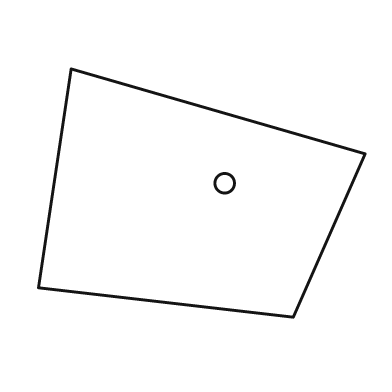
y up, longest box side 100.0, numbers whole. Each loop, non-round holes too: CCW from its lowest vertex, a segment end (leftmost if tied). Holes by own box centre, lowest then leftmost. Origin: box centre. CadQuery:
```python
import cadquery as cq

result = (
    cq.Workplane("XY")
    .moveTo(28.0, -38.0)
    .lineTo(50.0, 12.0)
    .lineTo(-40.0, 38.0)
    .lineTo(-50.0, -29.0)
    .close()
    .moveTo(7.0, 3.0)
    .circle(3.0)
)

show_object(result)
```